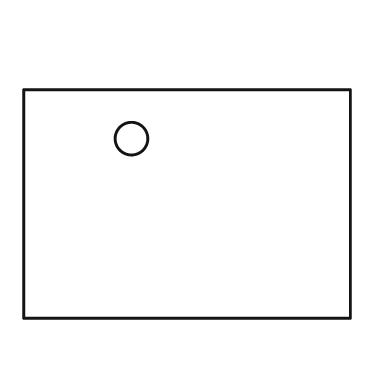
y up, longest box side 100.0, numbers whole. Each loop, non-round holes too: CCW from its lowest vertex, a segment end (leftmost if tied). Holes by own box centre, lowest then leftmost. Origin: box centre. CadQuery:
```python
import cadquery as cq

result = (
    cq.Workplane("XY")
    .moveTo(-50.0, -35.0)
    .lineTo(50.0, -35.0)
    .lineTo(50.0, 35.0)
    .lineTo(-50.0, 35.0)
    .close()
    .moveTo(-17.0, 20.0)
    .circle(5.0)
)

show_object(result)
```